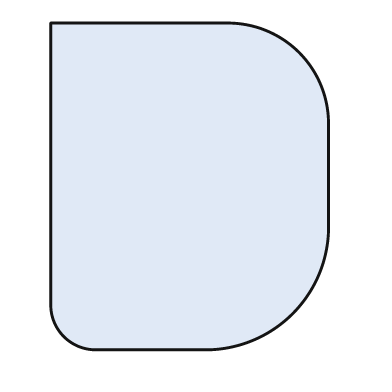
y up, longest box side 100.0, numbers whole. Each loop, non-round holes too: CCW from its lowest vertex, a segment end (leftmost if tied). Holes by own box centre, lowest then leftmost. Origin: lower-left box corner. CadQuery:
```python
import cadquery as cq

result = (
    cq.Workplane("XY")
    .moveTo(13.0, 0.0)
    .lineTo(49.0, 0.0)
    .threePointArc((74.0, 11.0), (85.0, 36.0))
    .lineTo(85.0, 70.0)
    .threePointArc((76.0, 91.0), (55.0, 100.0))
    .lineTo(0.0, 100.0)
    .lineTo(0.0, 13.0)
    .threePointArc((4.0, 4.0), (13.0, 0.0))
    .close()
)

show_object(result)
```